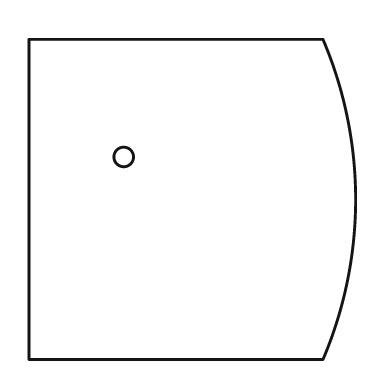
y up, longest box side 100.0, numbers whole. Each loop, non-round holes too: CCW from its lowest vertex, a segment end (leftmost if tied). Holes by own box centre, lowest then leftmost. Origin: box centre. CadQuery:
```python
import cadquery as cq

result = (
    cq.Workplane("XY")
    .moveTo(-50.0, -49.0)
    .lineTo(40.0, -49.0)
    .threePointArc((50.0, 0.0), (40.0, 49.0))
    .lineTo(-50.0, 49.0)
    .close()
    .moveTo(-21.0, 13.0)
    .circle(3.0)
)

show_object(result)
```